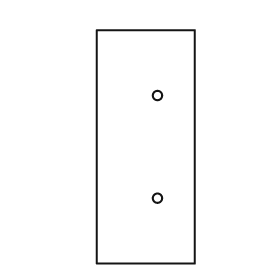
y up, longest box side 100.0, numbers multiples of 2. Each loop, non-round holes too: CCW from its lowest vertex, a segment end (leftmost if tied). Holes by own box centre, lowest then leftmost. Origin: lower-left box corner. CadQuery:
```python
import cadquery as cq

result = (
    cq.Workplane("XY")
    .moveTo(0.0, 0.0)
    .lineTo(42.0, 0.0)
    .lineTo(42.0, 100.0)
    .lineTo(0.0, 100.0)
    .close()
    .moveTo(26.0, 28.0)
    .circle(2.0)
    .moveTo(26.0, 72.0)
    .circle(2.0)
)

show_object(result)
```